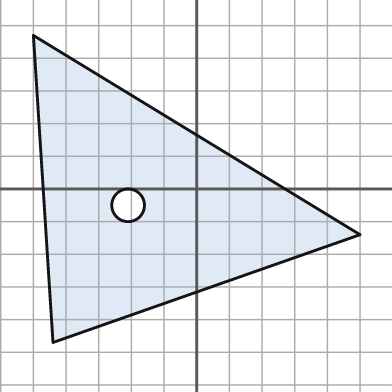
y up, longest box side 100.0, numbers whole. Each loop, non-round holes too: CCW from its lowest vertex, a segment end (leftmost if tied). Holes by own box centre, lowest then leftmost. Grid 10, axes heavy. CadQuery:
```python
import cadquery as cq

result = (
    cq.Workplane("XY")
    .moveTo(-44.0, -47.0)
    .lineTo(50.0, -14.0)
    .lineTo(-50.0, 47.0)
    .close()
    .moveTo(-21.0, -5.0)
    .circle(5.0)
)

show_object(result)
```